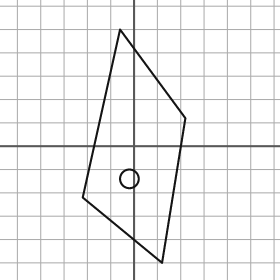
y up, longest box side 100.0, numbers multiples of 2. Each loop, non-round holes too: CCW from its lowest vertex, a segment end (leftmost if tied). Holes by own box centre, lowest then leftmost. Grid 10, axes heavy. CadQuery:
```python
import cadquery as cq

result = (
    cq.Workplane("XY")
    .moveTo(12.0, -50.0)
    .lineTo(22.0, 12.0)
    .lineTo(-6.0, 50.0)
    .lineTo(-22.0, -22.0)
    .close()
    .moveTo(-2.0, -14.0)
    .circle(4.0)
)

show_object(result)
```